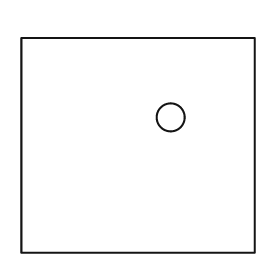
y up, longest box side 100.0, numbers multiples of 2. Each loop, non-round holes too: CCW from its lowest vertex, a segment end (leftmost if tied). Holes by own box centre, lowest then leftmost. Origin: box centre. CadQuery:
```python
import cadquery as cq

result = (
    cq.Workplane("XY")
    .moveTo(-50.0, -46.0)
    .lineTo(50.0, -46.0)
    .lineTo(50.0, 46.0)
    .lineTo(-50.0, 46.0)
    .close()
    .moveTo(14.0, 12.0)
    .circle(6.0)
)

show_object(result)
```